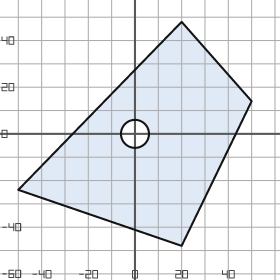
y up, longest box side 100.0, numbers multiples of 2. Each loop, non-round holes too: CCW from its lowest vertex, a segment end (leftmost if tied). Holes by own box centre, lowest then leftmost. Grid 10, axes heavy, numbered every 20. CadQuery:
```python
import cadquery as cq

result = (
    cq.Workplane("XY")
    .moveTo(20.0, -48.0)
    .lineTo(50.0, 14.0)
    .lineTo(20.0, 48.0)
    .lineTo(-50.0, -24.0)
    .close()
    .moveTo(0.0, 0.0)
    .circle(6.0)
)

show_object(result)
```